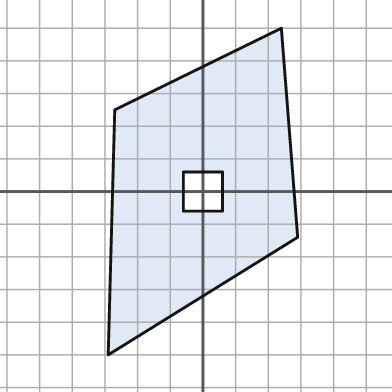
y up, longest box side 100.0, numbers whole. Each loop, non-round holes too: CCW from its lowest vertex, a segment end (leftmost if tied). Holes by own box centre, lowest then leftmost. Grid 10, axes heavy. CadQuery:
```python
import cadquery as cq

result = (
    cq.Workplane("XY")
    .moveTo(-29.0, -50.0)
    .lineTo(29.0, -14.0)
    .lineTo(24.0, 50.0)
    .lineTo(-27.0, 25.0)
    .close()
    .moveTo(-6.0, -6.0)
    .lineTo(6.0, -6.0)
    .lineTo(6.0, 6.0)
    .lineTo(-6.0, 6.0)
    .close()
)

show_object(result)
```